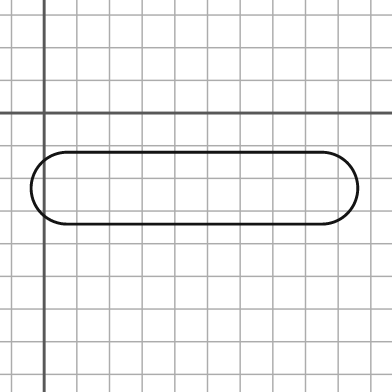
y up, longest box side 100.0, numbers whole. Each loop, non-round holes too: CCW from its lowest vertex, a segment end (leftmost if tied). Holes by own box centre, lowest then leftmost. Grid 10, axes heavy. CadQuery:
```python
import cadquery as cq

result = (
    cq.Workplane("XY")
    .moveTo(7.0, -34.0)
    .lineTo(85.0, -34.0)
    .threePointArc((96.0, -23.0), (85.0, -12.0))
    .lineTo(7.0, -12.0)
    .threePointArc((-4.0, -23.0), (7.0, -34.0))
    .close()
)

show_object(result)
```